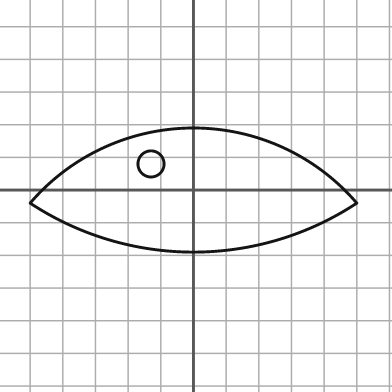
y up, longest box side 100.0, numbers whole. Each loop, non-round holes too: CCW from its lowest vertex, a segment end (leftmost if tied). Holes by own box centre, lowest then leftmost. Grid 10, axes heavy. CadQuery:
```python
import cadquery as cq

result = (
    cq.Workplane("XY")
    .moveTo(-50.0, -4.0)
    .threePointArc((0.0, -19.0), (50.0, -4.0))
    .threePointArc((0.0, 19.0), (-50.0, -4.0))
    .close()
    .moveTo(-13.0, 8.0)
    .circle(4.0)
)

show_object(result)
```